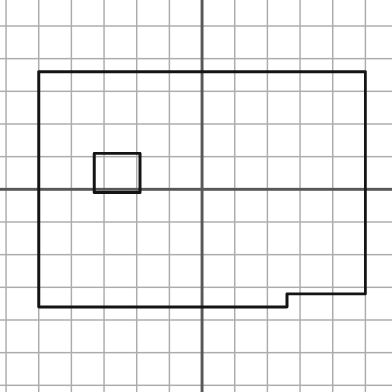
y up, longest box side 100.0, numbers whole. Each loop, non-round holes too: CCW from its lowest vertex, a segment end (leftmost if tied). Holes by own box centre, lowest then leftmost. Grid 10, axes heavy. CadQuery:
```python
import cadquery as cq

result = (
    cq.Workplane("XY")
    .moveTo(-50.0, -36.0)
    .lineTo(26.0, -36.0)
    .lineTo(26.0, -32.0)
    .lineTo(50.0, -32.0)
    .lineTo(50.0, 36.0)
    .lineTo(-50.0, 36.0)
    .close()
    .moveTo(-33.0, -1.0)
    .lineTo(-19.0, -1.0)
    .lineTo(-19.0, 11.0)
    .lineTo(-33.0, 11.0)
    .close()
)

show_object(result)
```